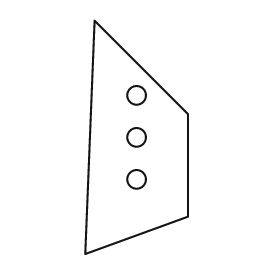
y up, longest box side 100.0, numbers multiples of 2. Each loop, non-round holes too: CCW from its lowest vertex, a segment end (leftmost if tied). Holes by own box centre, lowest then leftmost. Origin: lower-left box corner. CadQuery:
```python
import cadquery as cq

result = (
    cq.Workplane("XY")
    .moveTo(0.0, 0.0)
    .lineTo(44.0, 16.0)
    .lineTo(44.0, 60.0)
    .lineTo(4.0, 100.0)
    .close()
    .moveTo(22.0, 32.0)
    .circle(4.0)
    .moveTo(22.0, 50.0)
    .circle(4.0)
    .moveTo(22.0, 68.0)
    .circle(4.0)
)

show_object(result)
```